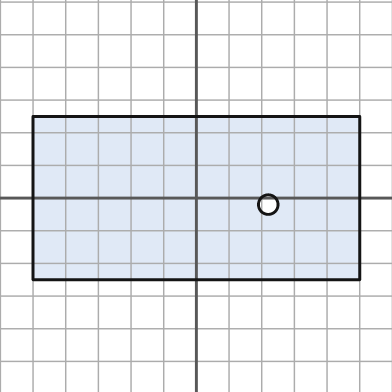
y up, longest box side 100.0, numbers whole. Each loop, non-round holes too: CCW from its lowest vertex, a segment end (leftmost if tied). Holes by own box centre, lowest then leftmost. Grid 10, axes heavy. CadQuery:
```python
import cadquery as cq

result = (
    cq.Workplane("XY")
    .moveTo(-50.0, -25.0)
    .lineTo(50.0, -25.0)
    .lineTo(50.0, 25.0)
    .lineTo(-50.0, 25.0)
    .close()
    .moveTo(22.0, -2.0)
    .circle(3.0)
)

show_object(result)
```